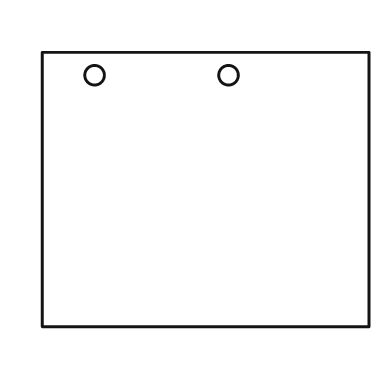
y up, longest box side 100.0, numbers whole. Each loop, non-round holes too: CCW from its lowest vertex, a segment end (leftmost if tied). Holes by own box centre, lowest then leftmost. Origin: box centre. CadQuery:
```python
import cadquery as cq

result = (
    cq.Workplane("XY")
    .moveTo(-50.0, -42.0)
    .lineTo(50.0, -42.0)
    .lineTo(50.0, 42.0)
    .lineTo(-50.0, 42.0)
    .close()
    .moveTo(-34.0, 35.0)
    .circle(3.0)
    .moveTo(7.0, 35.0)
    .circle(3.0)
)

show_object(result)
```